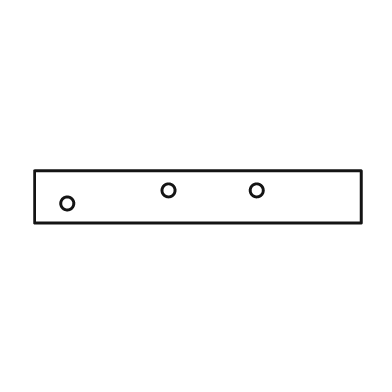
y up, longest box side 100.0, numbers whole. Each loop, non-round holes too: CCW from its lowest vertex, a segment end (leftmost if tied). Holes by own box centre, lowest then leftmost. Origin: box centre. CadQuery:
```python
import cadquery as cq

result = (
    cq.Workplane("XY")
    .moveTo(-50.0, -8.0)
    .lineTo(50.0, -8.0)
    .lineTo(50.0, 8.0)
    .lineTo(-50.0, 8.0)
    .close()
    .moveTo(-40.0, -2.0)
    .circle(2.0)
    .moveTo(-9.0, 2.0)
    .circle(2.0)
    .moveTo(18.0, 2.0)
    .circle(2.0)
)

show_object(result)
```